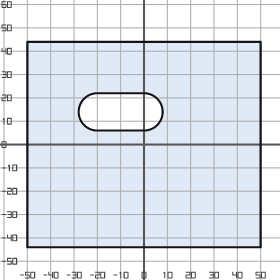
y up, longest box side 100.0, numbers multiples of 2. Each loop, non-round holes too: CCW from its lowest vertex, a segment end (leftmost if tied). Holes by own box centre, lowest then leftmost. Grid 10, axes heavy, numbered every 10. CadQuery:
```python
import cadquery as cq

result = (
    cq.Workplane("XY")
    .moveTo(-50.0, -44.0)
    .lineTo(50.0, -44.0)
    .lineTo(50.0, 44.0)
    .lineTo(-50.0, 44.0)
    .close()
    .moveTo(-20.0, 6.0)
    .lineTo(0.0, 6.0)
    .threePointArc((8.0, 14.0), (0.0, 22.0))
    .lineTo(-20.0, 22.0)
    .threePointArc((-28.0, 14.0), (-20.0, 6.0))
    .close()
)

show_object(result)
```